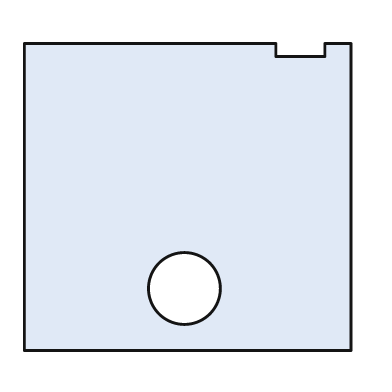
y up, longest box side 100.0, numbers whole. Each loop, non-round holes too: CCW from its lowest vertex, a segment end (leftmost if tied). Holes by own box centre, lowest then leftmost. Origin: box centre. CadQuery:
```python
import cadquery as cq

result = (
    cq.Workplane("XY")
    .moveTo(-50.0, -47.0)
    .lineTo(50.0, -47.0)
    .lineTo(50.0, 47.0)
    .lineTo(42.0, 47.0)
    .lineTo(42.0, 43.0)
    .lineTo(27.0, 43.0)
    .lineTo(27.0, 47.0)
    .lineTo(-50.0, 47.0)
    .close()
    .moveTo(-1.0, -28.0)
    .circle(11.0)
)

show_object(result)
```